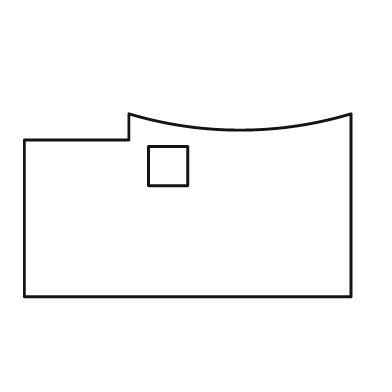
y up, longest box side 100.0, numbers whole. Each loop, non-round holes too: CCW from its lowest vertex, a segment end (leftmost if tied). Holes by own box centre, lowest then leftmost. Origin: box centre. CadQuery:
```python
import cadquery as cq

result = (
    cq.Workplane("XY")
    .moveTo(-50.0, -28.0)
    .lineTo(50.0, -28.0)
    .lineTo(50.0, 28.0)
    .threePointArc((16.0, 23.0), (-18.0, 28.0))
    .lineTo(-18.0, 20.0)
    .lineTo(-50.0, 20.0)
    .close()
    .moveTo(-12.0, 6.0)
    .lineTo(0.0, 6.0)
    .lineTo(0.0, 18.0)
    .lineTo(-12.0, 18.0)
    .close()
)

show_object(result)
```